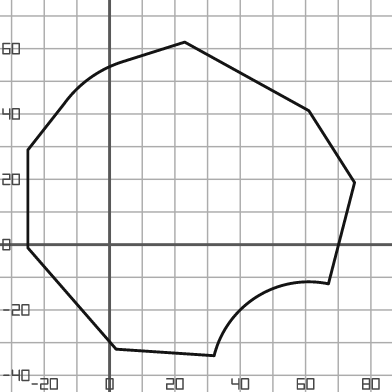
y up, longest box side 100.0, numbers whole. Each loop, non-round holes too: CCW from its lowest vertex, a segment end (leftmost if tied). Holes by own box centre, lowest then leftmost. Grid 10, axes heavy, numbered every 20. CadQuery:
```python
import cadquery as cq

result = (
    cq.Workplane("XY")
    .moveTo(32.0, -34.0)
    .threePointArc((45.0, -16.0), (67.0, -12.0))
    .lineTo(75.0, 19.0)
    .lineTo(61.0, 41.0)
    .lineTo(23.0, 62.0)
    .lineTo(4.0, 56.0)
    .threePointArc((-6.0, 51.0), (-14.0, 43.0))
    .lineTo(-25.0, 29.0)
    .lineTo(-25.0, -1.0)
    .lineTo(2.0, -32.0)
    .close()
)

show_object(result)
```